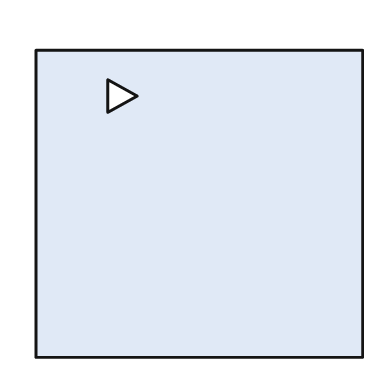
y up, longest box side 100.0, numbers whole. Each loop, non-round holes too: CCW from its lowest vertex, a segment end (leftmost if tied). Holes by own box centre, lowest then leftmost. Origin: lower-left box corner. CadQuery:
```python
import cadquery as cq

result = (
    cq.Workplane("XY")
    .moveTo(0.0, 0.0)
    .lineTo(100.0, 0.0)
    .lineTo(100.0, 94.0)
    .lineTo(0.0, 94.0)
    .close()
    .moveTo(22.0, 75.0)
    .lineTo(31.0, 80.0)
    .lineTo(22.0, 85.0)
    .close()
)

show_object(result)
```